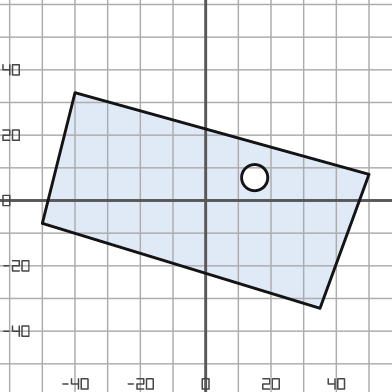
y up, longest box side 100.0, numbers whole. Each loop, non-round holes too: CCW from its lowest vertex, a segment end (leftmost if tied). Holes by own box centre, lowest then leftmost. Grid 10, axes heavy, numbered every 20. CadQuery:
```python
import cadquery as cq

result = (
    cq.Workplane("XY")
    .moveTo(35.0, -33.0)
    .lineTo(50.0, 8.0)
    .lineTo(-40.0, 33.0)
    .lineTo(-50.0, -7.0)
    .close()
    .moveTo(15.0, 7.0)
    .circle(4.0)
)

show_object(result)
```